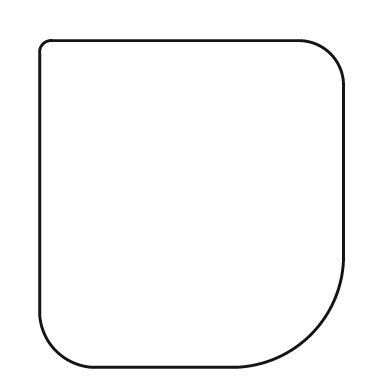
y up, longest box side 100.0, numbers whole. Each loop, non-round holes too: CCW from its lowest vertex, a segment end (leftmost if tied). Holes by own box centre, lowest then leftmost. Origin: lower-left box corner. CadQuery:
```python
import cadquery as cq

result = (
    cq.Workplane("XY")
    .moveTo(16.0, 0.0)
    .lineTo(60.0, 0.0)
    .threePointArc((83.0, 10.0), (93.0, 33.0))
    .lineTo(93.0, 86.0)
    .threePointArc((89.0, 96.0), (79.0, 100.0))
    .lineTo(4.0, 100.0)
    .threePointArc((1.0, 99.0), (0.0, 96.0))
    .lineTo(0.0, 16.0)
    .threePointArc((5.0, 5.0), (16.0, 0.0))
    .close()
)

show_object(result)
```